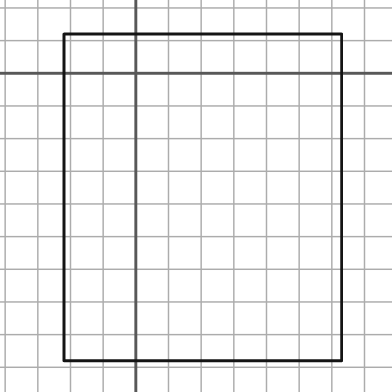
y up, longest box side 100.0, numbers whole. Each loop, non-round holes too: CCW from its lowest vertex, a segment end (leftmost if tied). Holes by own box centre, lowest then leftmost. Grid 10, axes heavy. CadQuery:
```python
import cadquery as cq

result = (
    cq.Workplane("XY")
    .moveTo(-22.0, -88.0)
    .lineTo(63.0, -88.0)
    .lineTo(63.0, 12.0)
    .lineTo(-22.0, 12.0)
    .close()
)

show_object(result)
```